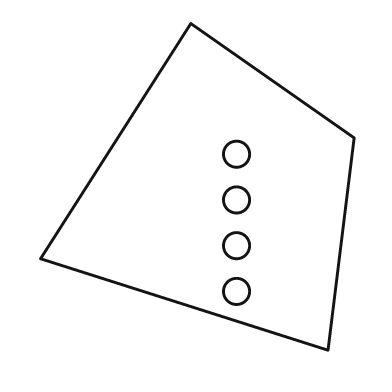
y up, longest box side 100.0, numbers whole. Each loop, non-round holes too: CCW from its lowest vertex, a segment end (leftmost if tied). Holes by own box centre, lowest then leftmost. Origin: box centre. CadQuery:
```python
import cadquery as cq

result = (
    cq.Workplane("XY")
    .moveTo(40.0, -50.0)
    .lineTo(48.0, 15.0)
    .lineTo(-2.0, 50.0)
    .lineTo(-48.0, -22.0)
    .close()
    .moveTo(12.0, -32.0)
    .circle(4.0)
    .moveTo(12.0, -18.0)
    .circle(4.0)
    .moveTo(12.0, -4.0)
    .circle(4.0)
    .moveTo(12.0, 10.0)
    .circle(4.0)
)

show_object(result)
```